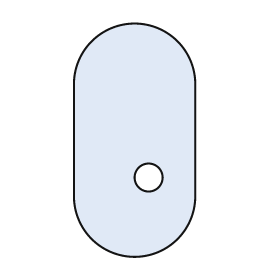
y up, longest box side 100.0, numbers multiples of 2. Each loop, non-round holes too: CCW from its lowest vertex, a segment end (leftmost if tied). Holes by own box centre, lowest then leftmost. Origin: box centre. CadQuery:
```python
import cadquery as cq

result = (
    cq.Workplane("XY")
    .moveTo(-26.0, -24.0)
    .threePointArc((0.0, -50.0), (26.0, -24.0))
    .lineTo(26.0, 24.0)
    .threePointArc((0.0, 50.0), (-26.0, 24.0))
    .close()
    .moveTo(6.0, -16.0)
    .circle(6.0)
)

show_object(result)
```